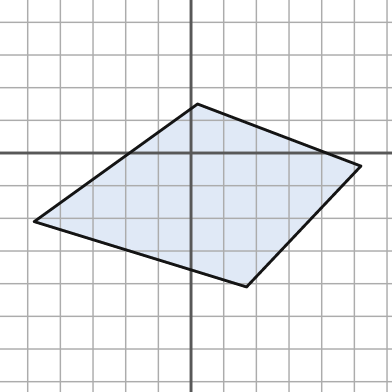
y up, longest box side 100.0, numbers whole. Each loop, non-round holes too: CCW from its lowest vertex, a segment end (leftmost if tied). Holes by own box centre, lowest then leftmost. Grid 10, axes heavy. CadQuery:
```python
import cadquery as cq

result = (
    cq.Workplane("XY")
    .moveTo(17.0, -41.0)
    .lineTo(52.0, -4.0)
    .lineTo(2.0, 15.0)
    .lineTo(-48.0, -21.0)
    .close()
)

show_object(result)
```